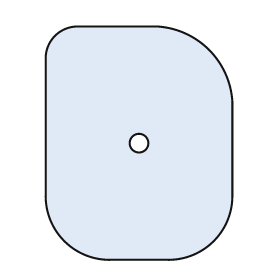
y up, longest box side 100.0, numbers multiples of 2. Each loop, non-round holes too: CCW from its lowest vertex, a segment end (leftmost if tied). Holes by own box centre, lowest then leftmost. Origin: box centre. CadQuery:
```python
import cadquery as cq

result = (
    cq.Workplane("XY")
    .moveTo(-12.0, -50.0)
    .lineTo(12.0, -50.0)
    .threePointArc((32.0, -42.0), (40.0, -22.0))
    .lineTo(40.0, 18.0)
    .threePointArc((30.0, 40.0), (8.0, 50.0))
    .lineTo(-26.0, 50.0)
    .threePointArc((-36.0, 46.0), (-40.0, 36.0))
    .lineTo(-40.0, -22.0)
    .threePointArc((-32.0, -42.0), (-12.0, -50.0))
    .close()
    .moveTo(0.0, 0.0)
    .circle(4.0)
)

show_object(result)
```